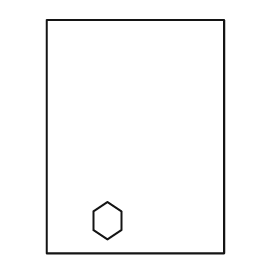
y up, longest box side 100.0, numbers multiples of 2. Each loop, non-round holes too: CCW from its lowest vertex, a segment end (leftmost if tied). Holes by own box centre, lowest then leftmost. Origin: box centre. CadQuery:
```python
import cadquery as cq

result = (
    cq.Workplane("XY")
    .moveTo(-38.0, -50.0)
    .lineTo(38.0, -50.0)
    .lineTo(38.0, 50.0)
    .lineTo(-38.0, 50.0)
    .close()
    .moveTo(-12.0, -44.0)
    .lineTo(-6.0, -40.0)
    .lineTo(-6.0, -32.0)
    .lineTo(-12.0, -28.0)
    .lineTo(-18.0, -32.0)
    .lineTo(-18.0, -40.0)
    .close()
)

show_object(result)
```